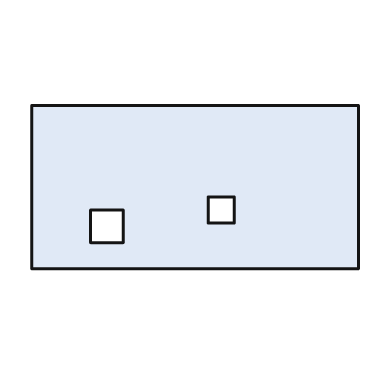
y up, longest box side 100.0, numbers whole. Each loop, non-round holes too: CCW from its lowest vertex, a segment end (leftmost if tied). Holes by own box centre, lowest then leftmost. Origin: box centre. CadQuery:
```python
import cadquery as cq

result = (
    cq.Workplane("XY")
    .moveTo(-50.0, -25.0)
    .lineTo(50.0, -25.0)
    .lineTo(50.0, 25.0)
    .lineTo(-50.0, 25.0)
    .close()
    .moveTo(-32.0, -17.0)
    .lineTo(-22.0, -17.0)
    .lineTo(-22.0, -7.0)
    .lineTo(-32.0, -7.0)
    .close()
    .moveTo(4.0, -11.0)
    .lineTo(12.0, -11.0)
    .lineTo(12.0, -3.0)
    .lineTo(4.0, -3.0)
    .close()
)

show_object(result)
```